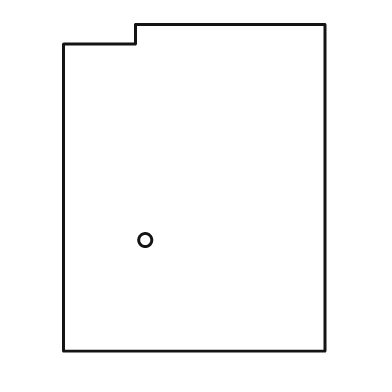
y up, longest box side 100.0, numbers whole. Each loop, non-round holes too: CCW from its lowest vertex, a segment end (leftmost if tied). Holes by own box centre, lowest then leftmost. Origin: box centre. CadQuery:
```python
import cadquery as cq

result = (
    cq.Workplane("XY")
    .moveTo(-40.0, -50.0)
    .lineTo(40.0, -50.0)
    .lineTo(40.0, 50.0)
    .lineTo(-18.0, 50.0)
    .lineTo(-18.0, 44.0)
    .lineTo(-40.0, 44.0)
    .close()
    .moveTo(-15.0, -16.0)
    .circle(2.0)
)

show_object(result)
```